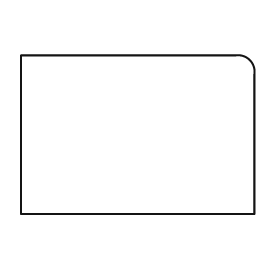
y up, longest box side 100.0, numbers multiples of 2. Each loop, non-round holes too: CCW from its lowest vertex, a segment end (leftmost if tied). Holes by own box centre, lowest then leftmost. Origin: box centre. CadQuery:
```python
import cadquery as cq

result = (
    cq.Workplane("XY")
    .moveTo(-50.0, -34.0)
    .lineTo(50.0, -34.0)
    .lineTo(50.0, 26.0)
    .threePointArc((48.0, 32.0), (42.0, 34.0))
    .lineTo(-50.0, 34.0)
    .close()
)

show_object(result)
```